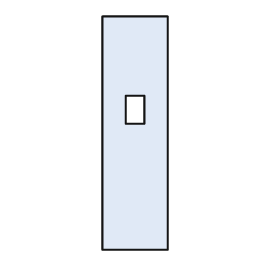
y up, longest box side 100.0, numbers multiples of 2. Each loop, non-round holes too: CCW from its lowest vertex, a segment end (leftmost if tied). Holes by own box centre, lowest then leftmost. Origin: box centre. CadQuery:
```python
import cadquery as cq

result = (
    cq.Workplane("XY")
    .moveTo(-14.0, -50.0)
    .lineTo(14.0, -50.0)
    .lineTo(14.0, 50.0)
    .lineTo(-14.0, 50.0)
    .close()
    .moveTo(-4.0, 4.0)
    .lineTo(4.0, 4.0)
    .lineTo(4.0, 16.0)
    .lineTo(-4.0, 16.0)
    .close()
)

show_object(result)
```